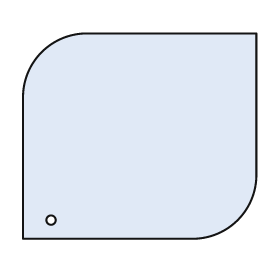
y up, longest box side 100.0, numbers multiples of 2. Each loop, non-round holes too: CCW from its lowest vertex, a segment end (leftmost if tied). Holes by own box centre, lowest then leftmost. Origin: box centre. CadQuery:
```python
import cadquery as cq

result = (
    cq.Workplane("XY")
    .moveTo(-50.0, -44.0)
    .lineTo(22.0, -44.0)
    .threePointArc((42.0, -36.0), (50.0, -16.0))
    .lineTo(50.0, 44.0)
    .lineTo(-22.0, 44.0)
    .threePointArc((-42.0, 36.0), (-50.0, 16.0))
    .close()
    .moveTo(-38.0, -36.0)
    .circle(2.0)
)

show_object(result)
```